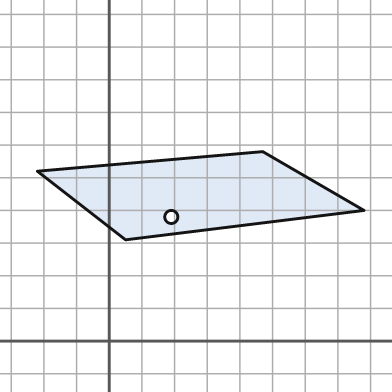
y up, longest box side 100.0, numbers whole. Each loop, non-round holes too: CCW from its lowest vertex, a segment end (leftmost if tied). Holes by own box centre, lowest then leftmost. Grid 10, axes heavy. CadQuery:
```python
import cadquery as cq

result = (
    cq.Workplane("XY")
    .moveTo(5.0, 31.0)
    .lineTo(78.0, 40.0)
    .lineTo(47.0, 58.0)
    .lineTo(-22.0, 52.0)
    .close()
    .moveTo(19.0, 38.0)
    .circle(2.0)
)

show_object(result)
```